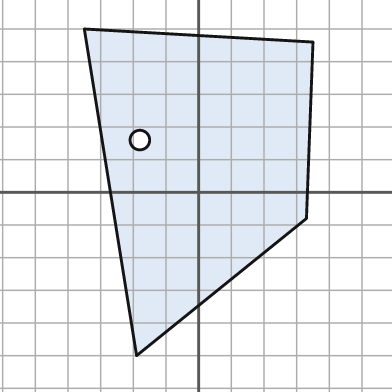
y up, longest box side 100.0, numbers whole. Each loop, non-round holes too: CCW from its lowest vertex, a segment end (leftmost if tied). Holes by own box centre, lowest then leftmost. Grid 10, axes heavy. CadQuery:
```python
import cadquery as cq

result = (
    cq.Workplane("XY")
    .moveTo(-19.0, -50.0)
    .lineTo(33.0, -8.0)
    .lineTo(35.0, 46.0)
    .lineTo(-35.0, 50.0)
    .close()
    .moveTo(-18.0, 16.0)
    .circle(3.0)
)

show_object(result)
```